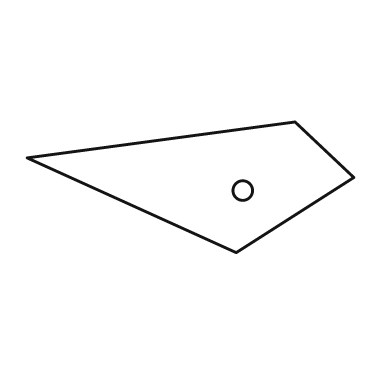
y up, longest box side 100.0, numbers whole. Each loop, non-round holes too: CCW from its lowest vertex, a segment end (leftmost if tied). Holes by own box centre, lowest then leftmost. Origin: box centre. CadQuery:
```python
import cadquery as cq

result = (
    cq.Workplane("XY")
    .moveTo(14.0, -20.0)
    .lineTo(50.0, 3.0)
    .lineTo(32.0, 20.0)
    .lineTo(-50.0, 9.0)
    .close()
    .moveTo(16.0, -1.0)
    .circle(3.0)
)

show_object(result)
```